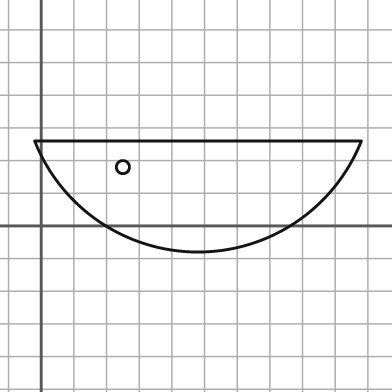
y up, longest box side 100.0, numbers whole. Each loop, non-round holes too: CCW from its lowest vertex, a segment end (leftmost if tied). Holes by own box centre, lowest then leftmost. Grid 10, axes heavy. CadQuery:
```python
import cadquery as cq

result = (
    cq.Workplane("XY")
    .moveTo(-2.0, 26.0)
    .threePointArc((48.0, -8.0), (98.0, 26.0))
    .close()
    .moveTo(25.0, 18.0)
    .circle(2.0)
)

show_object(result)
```